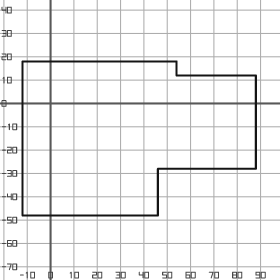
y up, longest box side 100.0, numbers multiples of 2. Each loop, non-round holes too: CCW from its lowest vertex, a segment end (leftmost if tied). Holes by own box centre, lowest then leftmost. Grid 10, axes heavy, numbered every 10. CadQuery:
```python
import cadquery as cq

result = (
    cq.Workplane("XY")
    .moveTo(-12.0, -48.0)
    .lineTo(46.0, -48.0)
    .lineTo(46.0, -28.0)
    .lineTo(88.0, -28.0)
    .lineTo(88.0, 12.0)
    .lineTo(54.0, 12.0)
    .lineTo(54.0, 18.0)
    .lineTo(-12.0, 18.0)
    .close()
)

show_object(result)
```